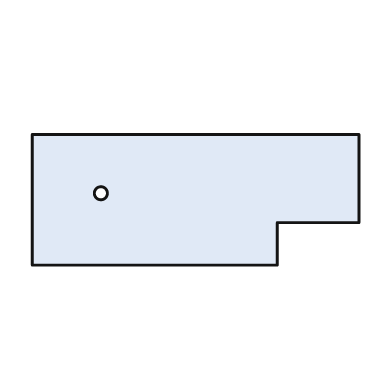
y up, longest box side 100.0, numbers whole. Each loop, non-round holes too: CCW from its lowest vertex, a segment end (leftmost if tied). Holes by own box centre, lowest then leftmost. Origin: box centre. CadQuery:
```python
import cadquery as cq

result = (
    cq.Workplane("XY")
    .moveTo(-50.0, -20.0)
    .lineTo(25.0, -20.0)
    .lineTo(25.0, -7.0)
    .lineTo(50.0, -7.0)
    .lineTo(50.0, 20.0)
    .lineTo(-50.0, 20.0)
    .close()
    .moveTo(-29.0, 2.0)
    .circle(2.0)
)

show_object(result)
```